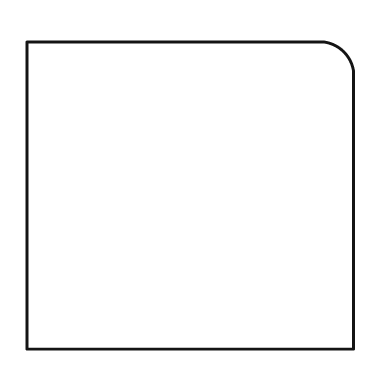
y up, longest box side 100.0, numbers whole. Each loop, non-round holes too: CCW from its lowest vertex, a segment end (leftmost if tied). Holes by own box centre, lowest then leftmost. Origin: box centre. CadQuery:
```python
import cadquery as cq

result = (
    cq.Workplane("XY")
    .moveTo(-50.0, -47.0)
    .lineTo(50.0, -47.0)
    .lineTo(50.0, 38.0)
    .threePointArc((47.0, 44.0), (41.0, 47.0))
    .lineTo(-50.0, 47.0)
    .close()
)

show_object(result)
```